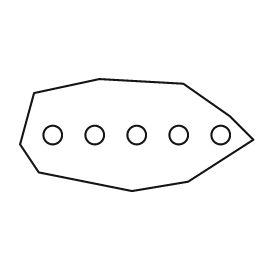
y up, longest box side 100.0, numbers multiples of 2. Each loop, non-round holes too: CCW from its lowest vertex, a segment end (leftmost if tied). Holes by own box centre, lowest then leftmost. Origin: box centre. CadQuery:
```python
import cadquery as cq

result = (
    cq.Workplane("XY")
    .moveTo(-2.0, -24.0)
    .lineTo(22.0, -20.0)
    .lineTo(50.0, -2.0)
    .lineTo(40.0, 8.0)
    .lineTo(20.0, 22.0)
    .lineTo(-16.0, 24.0)
    .lineTo(-44.0, 18.0)
    .lineTo(-50.0, -4.0)
    .lineTo(-42.0, -16.0)
    .close()
    .moveTo(-36.0, 0.0)
    .circle(4.0)
    .moveTo(-18.0, 0.0)
    .circle(4.0)
    .moveTo(0.0, 0.0)
    .circle(4.0)
    .moveTo(18.0, 0.0)
    .circle(4.0)
    .moveTo(36.0, 0.0)
    .circle(4.0)
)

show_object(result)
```